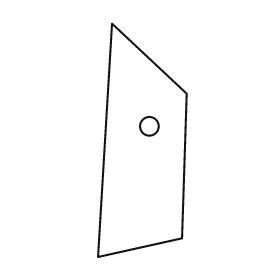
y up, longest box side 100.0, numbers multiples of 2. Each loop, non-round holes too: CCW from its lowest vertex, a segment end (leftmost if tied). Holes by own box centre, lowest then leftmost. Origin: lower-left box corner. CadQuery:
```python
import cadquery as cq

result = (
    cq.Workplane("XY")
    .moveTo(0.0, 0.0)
    .lineTo(36.0, 8.0)
    .lineTo(38.0, 70.0)
    .lineTo(6.0, 100.0)
    .close()
    .moveTo(22.0, 56.0)
    .circle(4.0)
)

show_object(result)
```